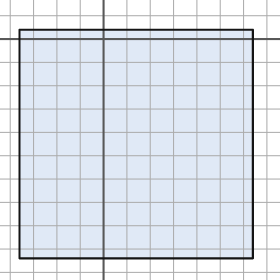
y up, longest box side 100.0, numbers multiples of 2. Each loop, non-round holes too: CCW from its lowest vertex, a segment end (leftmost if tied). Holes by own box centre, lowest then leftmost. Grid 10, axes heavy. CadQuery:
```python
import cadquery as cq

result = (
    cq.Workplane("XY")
    .moveTo(-36.0, -94.0)
    .lineTo(64.0, -94.0)
    .lineTo(64.0, 4.0)
    .lineTo(-36.0, 4.0)
    .close()
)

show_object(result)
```